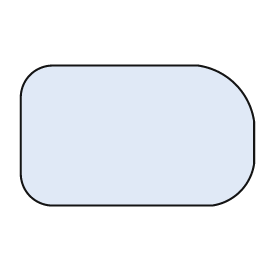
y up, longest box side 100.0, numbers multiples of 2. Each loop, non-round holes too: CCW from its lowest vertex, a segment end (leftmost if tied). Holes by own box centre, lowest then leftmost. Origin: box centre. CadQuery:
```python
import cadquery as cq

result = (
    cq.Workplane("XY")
    .moveTo(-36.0, -30.0)
    .lineTo(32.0, -30.0)
    .threePointArc((44.0, -24.0), (50.0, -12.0))
    .lineTo(50.0, 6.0)
    .threePointArc((42.0, 22.0), (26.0, 30.0))
    .lineTo(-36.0, 30.0)
    .threePointArc((-46.0, 26.0), (-50.0, 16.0))
    .lineTo(-50.0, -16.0)
    .threePointArc((-46.0, -26.0), (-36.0, -30.0))
    .close()
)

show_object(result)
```